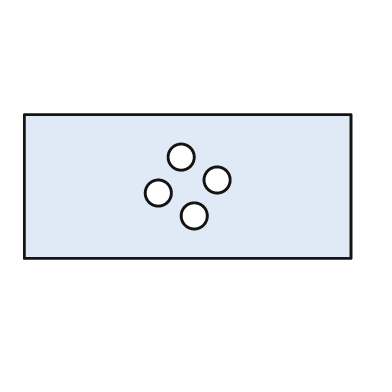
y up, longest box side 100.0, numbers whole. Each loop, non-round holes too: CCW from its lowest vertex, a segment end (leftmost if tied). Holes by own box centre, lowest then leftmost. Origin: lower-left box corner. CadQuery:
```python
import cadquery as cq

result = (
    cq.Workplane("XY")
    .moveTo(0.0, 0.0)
    .lineTo(100.0, 0.0)
    .lineTo(100.0, 44.0)
    .lineTo(0.0, 44.0)
    .close()
    .moveTo(52.0, 13.0)
    .circle(4.0)
    .moveTo(41.0, 20.0)
    .circle(4.0)
    .moveTo(59.0, 24.0)
    .circle(4.0)
    .moveTo(48.0, 31.0)
    .circle(4.0)
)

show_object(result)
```